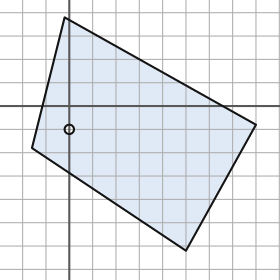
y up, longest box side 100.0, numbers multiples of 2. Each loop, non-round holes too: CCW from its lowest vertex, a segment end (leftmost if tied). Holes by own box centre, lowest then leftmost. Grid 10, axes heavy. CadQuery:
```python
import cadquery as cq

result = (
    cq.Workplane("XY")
    .moveTo(50.0, -62.0)
    .lineTo(80.0, -8.0)
    .lineTo(-2.0, 38.0)
    .lineTo(-16.0, -18.0)
    .close()
    .moveTo(0.0, -10.0)
    .circle(2.0)
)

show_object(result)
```